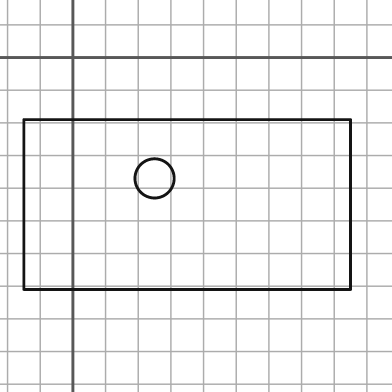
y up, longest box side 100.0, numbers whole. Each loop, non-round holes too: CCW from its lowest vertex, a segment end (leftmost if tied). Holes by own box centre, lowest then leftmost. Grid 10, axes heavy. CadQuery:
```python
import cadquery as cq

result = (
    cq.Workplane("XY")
    .moveTo(-15.0, -71.0)
    .lineTo(85.0, -71.0)
    .lineTo(85.0, -19.0)
    .lineTo(-15.0, -19.0)
    .close()
    .moveTo(25.0, -37.0)
    .circle(6.0)
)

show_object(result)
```